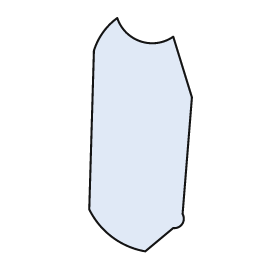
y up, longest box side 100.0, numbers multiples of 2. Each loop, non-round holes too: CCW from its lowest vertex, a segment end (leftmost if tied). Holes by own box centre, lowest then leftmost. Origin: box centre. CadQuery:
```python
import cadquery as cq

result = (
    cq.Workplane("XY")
    .moveTo(2.0, -50.0)
    .lineTo(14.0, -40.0)
    .threePointArc((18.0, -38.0), (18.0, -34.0))
    .lineTo(22.0, 16.0)
    .lineTo(14.0, 42.0)
    .threePointArc((0.0, 40.0), (-10.0, 50.0))
    .threePointArc((-16.0, 44.0), (-20.0, 36.0))
    .lineTo(-22.0, -32.0)
    .threePointArc((-12.0, -44.0), (2.0, -50.0))
    .close()
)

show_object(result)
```